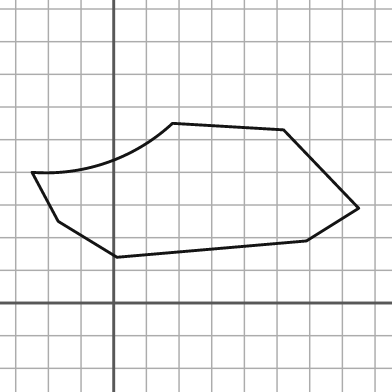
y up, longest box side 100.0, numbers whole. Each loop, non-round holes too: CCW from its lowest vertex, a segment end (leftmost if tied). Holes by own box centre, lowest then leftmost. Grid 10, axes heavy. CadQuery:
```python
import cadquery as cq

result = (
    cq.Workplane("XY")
    .moveTo(1.0, 14.0)
    .lineTo(59.0, 19.0)
    .lineTo(75.0, 29.0)
    .lineTo(52.0, 53.0)
    .lineTo(18.0, 55.0)
    .threePointArc((-2.0, 43.0), (-25.0, 40.0))
    .lineTo(-17.0, 25.0)
    .close()
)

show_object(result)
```